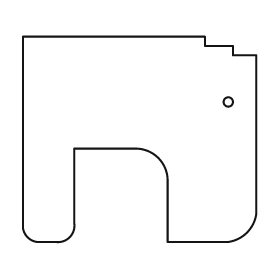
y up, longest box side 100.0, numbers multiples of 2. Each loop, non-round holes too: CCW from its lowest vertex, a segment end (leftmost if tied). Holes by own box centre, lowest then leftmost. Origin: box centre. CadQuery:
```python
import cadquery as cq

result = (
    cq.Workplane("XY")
    .moveTo(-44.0, -44.0)
    .lineTo(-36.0, -44.0)
    .threePointArc((-30.0, -42.0), (-28.0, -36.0))
    .lineTo(-28.0, -4.0)
    .lineTo(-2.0, -4.0)
    .threePointArc((8.0, -8.0), (12.0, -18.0))
    .lineTo(12.0, -44.0)
    .lineTo(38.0, -44.0)
    .threePointArc((46.0, -40.0), (50.0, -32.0))
    .lineTo(50.0, 36.0)
    .lineTo(40.0, 36.0)
    .lineTo(40.0, 40.0)
    .lineTo(28.0, 40.0)
    .lineTo(28.0, 44.0)
    .lineTo(-50.0, 44.0)
    .lineTo(-50.0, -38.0)
    .threePointArc((-48.0, -42.0), (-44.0, -44.0))
    .close()
    .moveTo(38.0, 16.0)
    .circle(2.0)
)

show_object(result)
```